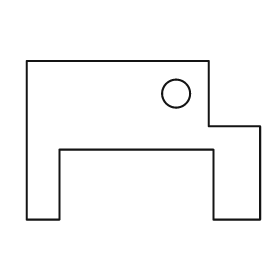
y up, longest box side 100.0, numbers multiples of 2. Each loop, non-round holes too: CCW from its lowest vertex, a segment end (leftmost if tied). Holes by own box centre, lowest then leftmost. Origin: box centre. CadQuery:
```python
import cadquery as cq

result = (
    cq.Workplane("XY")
    .moveTo(-50.0, -34.0)
    .lineTo(-36.0, -34.0)
    .lineTo(-36.0, -4.0)
    .lineTo(30.0, -4.0)
    .lineTo(30.0, -34.0)
    .lineTo(50.0, -34.0)
    .lineTo(50.0, 6.0)
    .lineTo(28.0, 6.0)
    .lineTo(28.0, 34.0)
    .lineTo(-50.0, 34.0)
    .close()
    .moveTo(14.0, 20.0)
    .circle(6.0)
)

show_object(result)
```